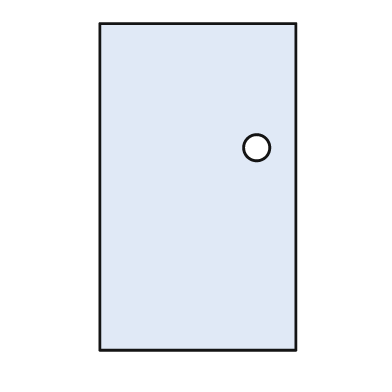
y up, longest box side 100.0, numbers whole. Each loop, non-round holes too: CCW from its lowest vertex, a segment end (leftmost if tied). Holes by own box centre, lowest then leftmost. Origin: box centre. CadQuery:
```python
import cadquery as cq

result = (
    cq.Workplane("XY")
    .moveTo(-30.0, -50.0)
    .lineTo(30.0, -50.0)
    .lineTo(30.0, 50.0)
    .lineTo(-30.0, 50.0)
    .close()
    .moveTo(18.0, 12.0)
    .circle(4.0)
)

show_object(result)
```